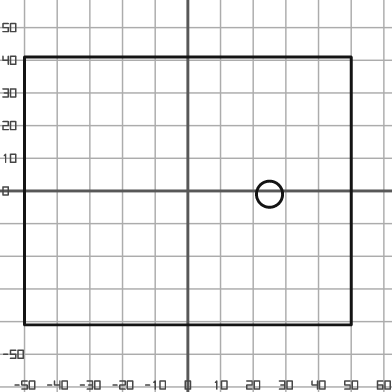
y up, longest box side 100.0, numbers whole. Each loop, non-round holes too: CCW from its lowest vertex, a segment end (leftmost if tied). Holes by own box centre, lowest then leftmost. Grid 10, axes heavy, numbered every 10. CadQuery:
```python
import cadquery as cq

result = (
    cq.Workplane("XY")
    .moveTo(-50.0, -41.0)
    .lineTo(50.0, -41.0)
    .lineTo(50.0, 41.0)
    .lineTo(-50.0, 41.0)
    .close()
    .moveTo(25.0, -1.0)
    .circle(4.0)
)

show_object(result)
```